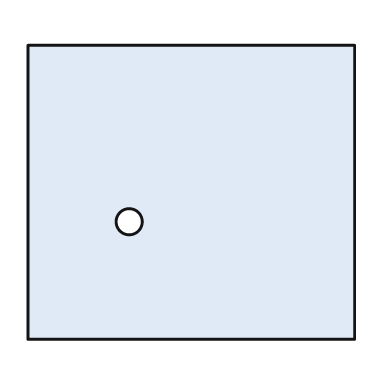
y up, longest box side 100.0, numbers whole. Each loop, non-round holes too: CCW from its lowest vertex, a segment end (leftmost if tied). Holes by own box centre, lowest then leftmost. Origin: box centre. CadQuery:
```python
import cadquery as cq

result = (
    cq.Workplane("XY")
    .moveTo(-50.0, -45.0)
    .lineTo(50.0, -45.0)
    .lineTo(50.0, 45.0)
    .lineTo(-50.0, 45.0)
    .close()
    .moveTo(-19.0, -9.0)
    .circle(4.0)
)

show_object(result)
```